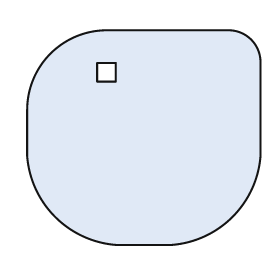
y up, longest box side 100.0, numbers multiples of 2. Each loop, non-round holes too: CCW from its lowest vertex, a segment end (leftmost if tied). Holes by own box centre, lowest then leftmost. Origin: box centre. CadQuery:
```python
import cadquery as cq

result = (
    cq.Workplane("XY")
    .moveTo(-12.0, -46.0)
    .lineTo(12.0, -46.0)
    .threePointArc((38.0, -34.0), (50.0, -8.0))
    .lineTo(50.0, 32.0)
    .threePointArc((46.0, 42.0), (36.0, 46.0))
    .lineTo(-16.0, 46.0)
    .threePointArc((-40.0, 36.0), (-50.0, 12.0))
    .lineTo(-50.0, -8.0)
    .threePointArc((-38.0, -34.0), (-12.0, -46.0))
    .close()
    .moveTo(-20.0, 24.0)
    .lineTo(-12.0, 24.0)
    .lineTo(-12.0, 32.0)
    .lineTo(-20.0, 32.0)
    .close()
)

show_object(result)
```